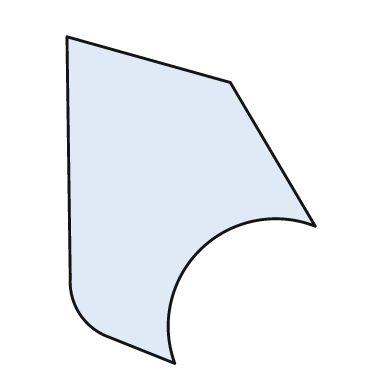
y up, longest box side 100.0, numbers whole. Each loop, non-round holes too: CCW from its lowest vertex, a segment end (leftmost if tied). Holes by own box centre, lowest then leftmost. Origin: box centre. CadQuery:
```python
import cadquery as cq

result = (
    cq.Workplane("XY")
    .moveTo(-5.0, -50.0)
    .threePointArc((3.0, -15.0), (38.0, -8.0))
    .lineTo(12.0, 36.0)
    .lineTo(-38.0, 50.0)
    .lineTo(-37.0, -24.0)
    .threePointArc((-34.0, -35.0), (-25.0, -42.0))
    .close()
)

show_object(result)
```